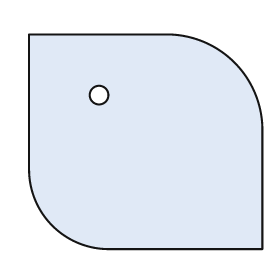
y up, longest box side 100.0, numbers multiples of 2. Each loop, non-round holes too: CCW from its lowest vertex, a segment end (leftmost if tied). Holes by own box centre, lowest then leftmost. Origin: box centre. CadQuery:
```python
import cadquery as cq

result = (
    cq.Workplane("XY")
    .moveTo(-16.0, -46.0)
    .lineTo(50.0, -46.0)
    .lineTo(50.0, 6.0)
    .threePointArc((38.0, 34.0), (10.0, 46.0))
    .lineTo(-50.0, 46.0)
    .lineTo(-50.0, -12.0)
    .threePointArc((-40.0, -36.0), (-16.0, -46.0))
    .close()
    .moveTo(-20.0, 20.0)
    .circle(4.0)
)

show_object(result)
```